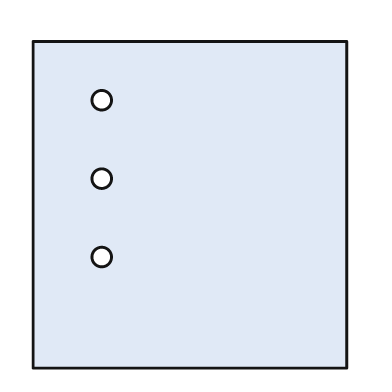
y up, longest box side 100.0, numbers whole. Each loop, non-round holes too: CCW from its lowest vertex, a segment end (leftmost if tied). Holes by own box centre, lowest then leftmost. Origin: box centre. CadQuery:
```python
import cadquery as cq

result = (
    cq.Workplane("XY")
    .moveTo(-48.0, -50.0)
    .lineTo(48.0, -50.0)
    .lineTo(48.0, 50.0)
    .lineTo(-48.0, 50.0)
    .close()
    .moveTo(-27.0, -16.0)
    .circle(3.0)
    .moveTo(-27.0, 8.0)
    .circle(3.0)
    .moveTo(-27.0, 32.0)
    .circle(3.0)
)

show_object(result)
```